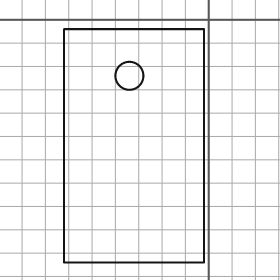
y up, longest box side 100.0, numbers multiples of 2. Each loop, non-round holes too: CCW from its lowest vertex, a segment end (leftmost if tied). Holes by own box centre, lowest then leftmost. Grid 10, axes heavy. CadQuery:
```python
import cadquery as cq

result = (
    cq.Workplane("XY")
    .moveTo(-62.0, -104.0)
    .lineTo(-2.0, -104.0)
    .lineTo(-2.0, -4.0)
    .lineTo(-62.0, -4.0)
    .close()
    .moveTo(-34.0, -24.0)
    .circle(6.0)
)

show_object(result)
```